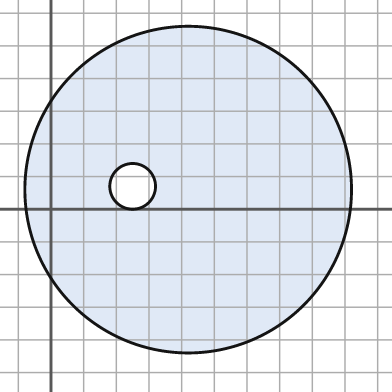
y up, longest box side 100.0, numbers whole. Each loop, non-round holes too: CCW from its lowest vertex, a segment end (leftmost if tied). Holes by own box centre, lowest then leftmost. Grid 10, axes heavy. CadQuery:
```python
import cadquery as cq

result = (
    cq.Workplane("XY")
    .moveTo(42.0, 6.0)
    .circle(50.0)
    .moveTo(25.0, 7.0)
    .circle(7.0)
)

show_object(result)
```